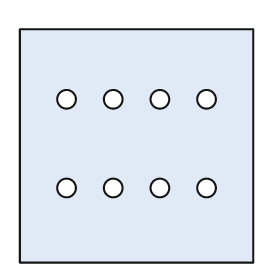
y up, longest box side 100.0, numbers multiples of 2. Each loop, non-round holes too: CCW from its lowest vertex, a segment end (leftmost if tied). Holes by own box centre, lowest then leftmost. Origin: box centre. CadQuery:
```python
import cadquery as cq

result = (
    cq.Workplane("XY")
    .moveTo(-50.0, -50.0)
    .lineTo(50.0, -50.0)
    .lineTo(50.0, 50.0)
    .lineTo(-50.0, 50.0)
    .close()
    .moveTo(-30.0, -18.0)
    .circle(4.0)
    .moveTo(-10.0, -18.0)
    .circle(4.0)
    .moveTo(10.0, -18.0)
    .circle(4.0)
    .moveTo(30.0, -18.0)
    .circle(4.0)
    .moveTo(-30.0, 20.0)
    .circle(4.0)
    .moveTo(-10.0, 20.0)
    .circle(4.0)
    .moveTo(10.0, 20.0)
    .circle(4.0)
    .moveTo(30.0, 20.0)
    .circle(4.0)
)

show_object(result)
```